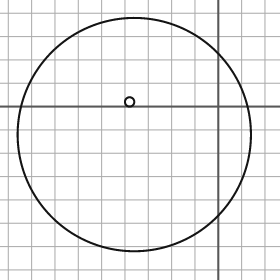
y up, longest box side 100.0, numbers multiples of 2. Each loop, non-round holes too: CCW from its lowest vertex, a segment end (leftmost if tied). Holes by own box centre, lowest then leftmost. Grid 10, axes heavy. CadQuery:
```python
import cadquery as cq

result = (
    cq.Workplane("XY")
    .moveTo(-36.0, -12.0)
    .circle(50.0)
    .moveTo(-38.0, 2.0)
    .circle(2.0)
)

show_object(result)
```